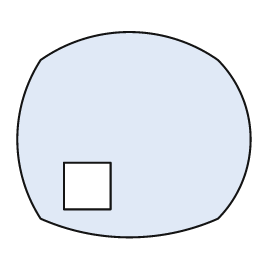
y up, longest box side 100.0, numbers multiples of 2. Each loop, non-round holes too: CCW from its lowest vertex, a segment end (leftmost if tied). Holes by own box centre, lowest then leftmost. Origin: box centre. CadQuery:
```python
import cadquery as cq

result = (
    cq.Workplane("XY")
    .moveTo(-40.0, -36.0)
    .threePointArc((-2.0, -44.0), (36.0, -36.0))
    .threePointArc((50.0, -2.0), (36.0, 32.0))
    .threePointArc((-2.0, 44.0), (-40.0, 32.0))
    .threePointArc((-50.0, -2.0), (-40.0, -36.0))
    .close()
    .moveTo(-30.0, -32.0)
    .lineTo(-10.0, -32.0)
    .lineTo(-10.0, -12.0)
    .lineTo(-30.0, -12.0)
    .close()
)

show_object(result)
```